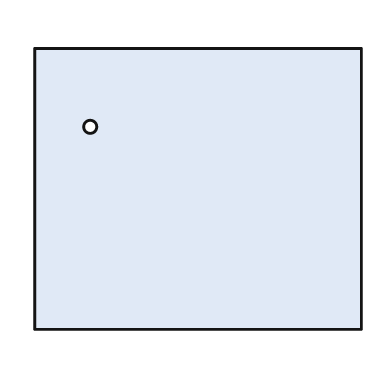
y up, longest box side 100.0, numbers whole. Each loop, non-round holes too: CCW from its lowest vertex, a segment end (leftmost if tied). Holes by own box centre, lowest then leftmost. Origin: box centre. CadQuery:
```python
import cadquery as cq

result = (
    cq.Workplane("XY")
    .moveTo(-50.0, -43.0)
    .lineTo(50.0, -43.0)
    .lineTo(50.0, 43.0)
    .lineTo(-50.0, 43.0)
    .close()
    .moveTo(-33.0, 19.0)
    .circle(2.0)
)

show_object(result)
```